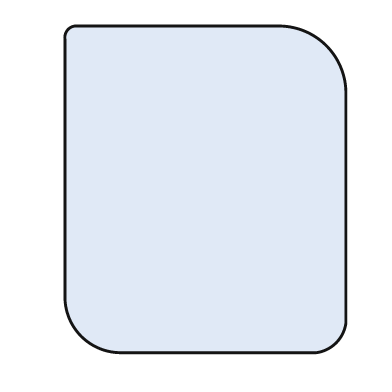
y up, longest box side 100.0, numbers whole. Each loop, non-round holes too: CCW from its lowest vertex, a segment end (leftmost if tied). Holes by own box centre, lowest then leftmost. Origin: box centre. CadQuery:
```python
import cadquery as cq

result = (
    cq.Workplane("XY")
    .moveTo(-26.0, -50.0)
    .lineTo(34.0, -50.0)
    .threePointArc((40.0, -47.0), (43.0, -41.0))
    .lineTo(43.0, 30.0)
    .threePointArc((37.0, 44.0), (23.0, 50.0))
    .lineTo(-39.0, 50.0)
    .threePointArc((-42.0, 49.0), (-43.0, 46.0))
    .lineTo(-43.0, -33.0)
    .threePointArc((-38.0, -45.0), (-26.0, -50.0))
    .close()
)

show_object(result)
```